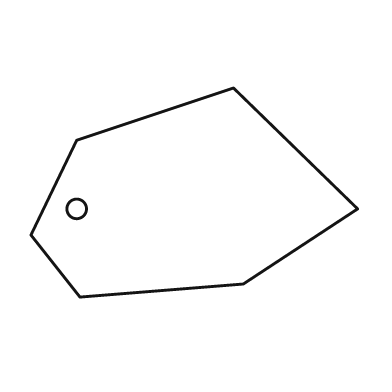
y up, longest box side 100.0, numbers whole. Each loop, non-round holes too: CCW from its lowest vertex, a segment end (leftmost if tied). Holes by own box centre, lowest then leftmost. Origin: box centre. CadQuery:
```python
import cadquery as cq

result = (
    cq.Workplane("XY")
    .moveTo(-35.0, -32.0)
    .lineTo(15.0, -28.0)
    .lineTo(50.0, -5.0)
    .lineTo(12.0, 32.0)
    .lineTo(-36.0, 16.0)
    .lineTo(-50.0, -13.0)
    .close()
    .moveTo(-36.0, -5.0)
    .circle(3.0)
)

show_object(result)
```